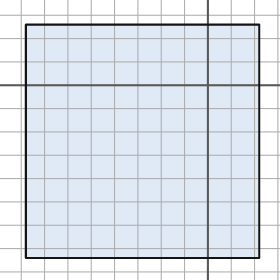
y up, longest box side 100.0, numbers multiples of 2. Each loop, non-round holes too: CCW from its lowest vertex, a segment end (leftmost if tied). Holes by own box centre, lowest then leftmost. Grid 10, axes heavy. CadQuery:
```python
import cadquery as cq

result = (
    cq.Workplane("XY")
    .moveTo(-78.0, -74.0)
    .lineTo(22.0, -74.0)
    .lineTo(22.0, 26.0)
    .lineTo(-78.0, 26.0)
    .close()
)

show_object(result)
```